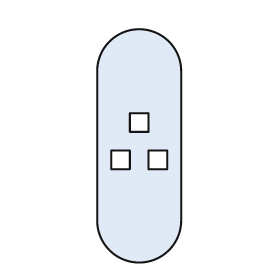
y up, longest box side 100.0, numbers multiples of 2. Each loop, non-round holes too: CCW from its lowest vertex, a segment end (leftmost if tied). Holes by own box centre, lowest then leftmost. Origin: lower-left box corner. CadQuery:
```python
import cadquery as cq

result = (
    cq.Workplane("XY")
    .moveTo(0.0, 18.0)
    .threePointArc((18.0, 0.0), (36.0, 18.0))
    .lineTo(36.0, 82.0)
    .threePointArc((18.0, 100.0), (0.0, 82.0))
    .close()
    .moveTo(6.0, 40.0)
    .lineTo(14.0, 40.0)
    .lineTo(14.0, 48.0)
    .lineTo(6.0, 48.0)
    .close()
    .moveTo(22.0, 40.0)
    .lineTo(30.0, 40.0)
    .lineTo(30.0, 48.0)
    .lineTo(22.0, 48.0)
    .close()
    .moveTo(14.0, 56.0)
    .lineTo(22.0, 56.0)
    .lineTo(22.0, 64.0)
    .lineTo(14.0, 64.0)
    .close()
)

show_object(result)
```